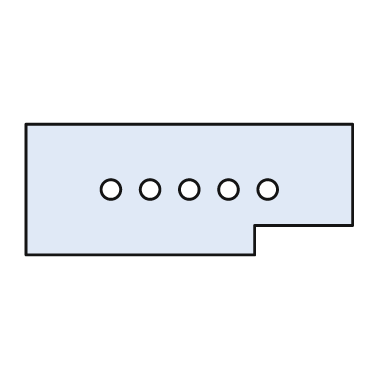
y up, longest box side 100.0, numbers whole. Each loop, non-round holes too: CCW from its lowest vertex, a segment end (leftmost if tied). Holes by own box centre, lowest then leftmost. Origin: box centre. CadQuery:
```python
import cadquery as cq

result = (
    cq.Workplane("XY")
    .moveTo(-50.0, -20.0)
    .lineTo(20.0, -20.0)
    .lineTo(20.0, -11.0)
    .lineTo(50.0, -11.0)
    .lineTo(50.0, 20.0)
    .lineTo(-50.0, 20.0)
    .close()
    .moveTo(-24.0, 0.0)
    .circle(3.0)
    .moveTo(-12.0, 0.0)
    .circle(3.0)
    .moveTo(0.0, 0.0)
    .circle(3.0)
    .moveTo(12.0, 0.0)
    .circle(3.0)
    .moveTo(24.0, 0.0)
    .circle(3.0)
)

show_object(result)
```